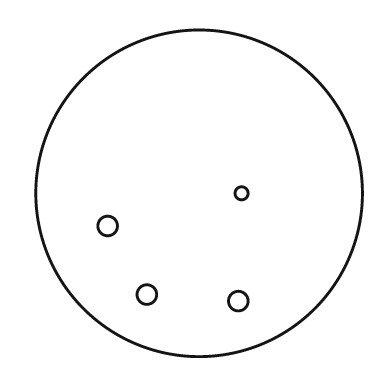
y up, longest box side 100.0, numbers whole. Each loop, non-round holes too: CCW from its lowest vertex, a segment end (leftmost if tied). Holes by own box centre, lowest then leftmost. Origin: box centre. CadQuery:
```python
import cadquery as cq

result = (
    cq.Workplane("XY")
    .moveTo(0.0, 0.0)
    .circle(50.0)
    .moveTo(12.0, -33.0)
    .circle(3.0)
    .moveTo(-16.0, -31.0)
    .circle(3.0)
    .moveTo(-28.0, -10.0)
    .circle(3.0)
    .moveTo(13.0, 0.0)
    .circle(2.0)
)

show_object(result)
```